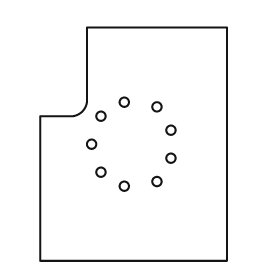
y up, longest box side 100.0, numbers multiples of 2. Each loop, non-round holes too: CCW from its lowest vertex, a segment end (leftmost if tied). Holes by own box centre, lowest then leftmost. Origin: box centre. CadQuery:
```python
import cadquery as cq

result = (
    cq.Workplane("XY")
    .moveTo(-40.0, -50.0)
    .lineTo(40.0, -50.0)
    .lineTo(40.0, 50.0)
    .lineTo(-20.0, 50.0)
    .lineTo(-20.0, 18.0)
    .threePointArc((-22.0, 14.0), (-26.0, 12.0))
    .lineTo(-40.0, 12.0)
    .close()
    .moveTo(-4.0, -18.0)
    .circle(2.0)
    .moveTo(10.0, -16.0)
    .circle(2.0)
    .moveTo(-14.0, -12.0)
    .circle(2.0)
    .moveTo(16.0, -6.0)
    .circle(2.0)
    .moveTo(-18.0, 0.0)
    .circle(2.0)
    .moveTo(16.0, 6.0)
    .circle(2.0)
    .moveTo(-14.0, 12.0)
    .circle(2.0)
    .moveTo(10.0, 16.0)
    .circle(2.0)
    .moveTo(-4.0, 18.0)
    .circle(2.0)
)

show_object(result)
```